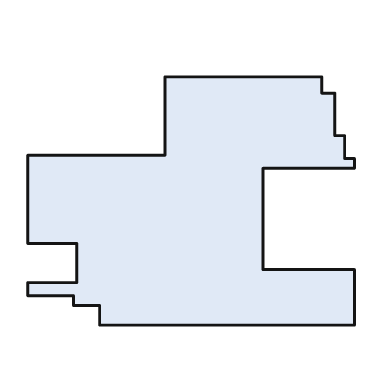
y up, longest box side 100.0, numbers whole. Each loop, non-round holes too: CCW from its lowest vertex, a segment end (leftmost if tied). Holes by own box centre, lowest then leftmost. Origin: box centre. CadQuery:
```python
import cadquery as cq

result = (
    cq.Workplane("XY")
    .moveTo(-28.0, -38.0)
    .lineTo(50.0, -38.0)
    .lineTo(50.0, -21.0)
    .lineTo(22.0, -21.0)
    .lineTo(22.0, 10.0)
    .lineTo(50.0, 10.0)
    .lineTo(50.0, 13.0)
    .lineTo(47.0, 13.0)
    .lineTo(47.0, 20.0)
    .lineTo(44.0, 20.0)
    .lineTo(44.0, 33.0)
    .lineTo(40.0, 33.0)
    .lineTo(40.0, 38.0)
    .lineTo(-8.0, 38.0)
    .lineTo(-8.0, 14.0)
    .lineTo(-50.0, 14.0)
    .lineTo(-50.0, -13.0)
    .lineTo(-35.0, -13.0)
    .lineTo(-35.0, -25.0)
    .lineTo(-50.0, -25.0)
    .lineTo(-50.0, -29.0)
    .lineTo(-36.0, -29.0)
    .lineTo(-36.0, -32.0)
    .lineTo(-28.0, -32.0)
    .close()
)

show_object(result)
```